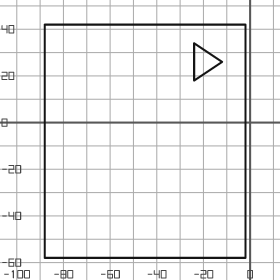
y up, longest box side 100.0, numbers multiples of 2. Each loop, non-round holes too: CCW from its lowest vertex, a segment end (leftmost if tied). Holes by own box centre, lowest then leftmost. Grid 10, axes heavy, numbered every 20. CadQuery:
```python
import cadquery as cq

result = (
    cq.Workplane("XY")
    .moveTo(-88.0, -58.0)
    .lineTo(-2.0, -58.0)
    .lineTo(-2.0, 42.0)
    .lineTo(-88.0, 42.0)
    .close()
    .moveTo(-24.0, 18.0)
    .lineTo(-12.0, 26.0)
    .lineTo(-24.0, 34.0)
    .close()
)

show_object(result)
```